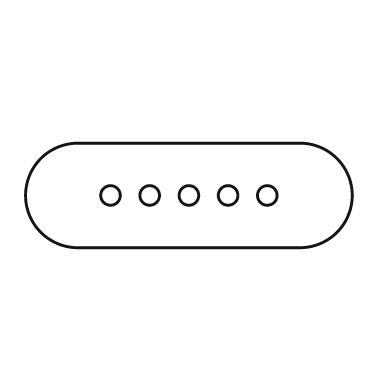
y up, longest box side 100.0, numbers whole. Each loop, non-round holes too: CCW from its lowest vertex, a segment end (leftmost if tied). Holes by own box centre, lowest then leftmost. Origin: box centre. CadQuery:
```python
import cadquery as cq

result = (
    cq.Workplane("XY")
    .moveTo(-34.0, -16.0)
    .lineTo(34.0, -16.0)
    .threePointArc((50.0, 0.0), (34.0, 16.0))
    .lineTo(-34.0, 16.0)
    .threePointArc((-50.0, 0.0), (-34.0, -16.0))
    .close()
    .moveTo(-24.0, 0.0)
    .circle(3.0)
    .moveTo(-12.0, 0.0)
    .circle(3.0)
    .moveTo(0.0, 0.0)
    .circle(3.0)
    .moveTo(12.0, 0.0)
    .circle(3.0)
    .moveTo(24.0, 0.0)
    .circle(3.0)
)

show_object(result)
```